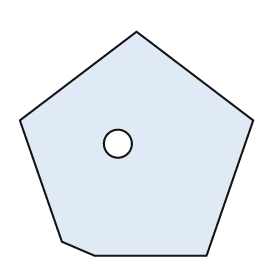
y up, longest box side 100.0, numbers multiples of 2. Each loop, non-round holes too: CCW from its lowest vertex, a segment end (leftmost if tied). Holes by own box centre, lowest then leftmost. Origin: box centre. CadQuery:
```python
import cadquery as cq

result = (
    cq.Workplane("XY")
    .moveTo(-18.0, -48.0)
    .lineTo(30.0, -48.0)
    .lineTo(50.0, 10.0)
    .lineTo(0.0, 48.0)
    .lineTo(-50.0, 10.0)
    .lineTo(-32.0, -42.0)
    .close()
    .moveTo(-8.0, 0.0)
    .circle(6.0)
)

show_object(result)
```